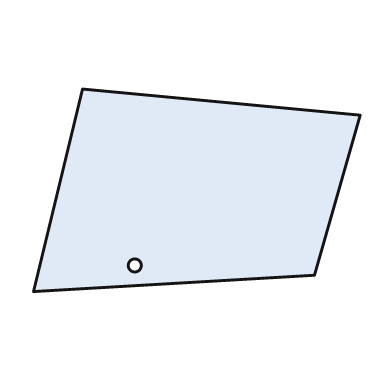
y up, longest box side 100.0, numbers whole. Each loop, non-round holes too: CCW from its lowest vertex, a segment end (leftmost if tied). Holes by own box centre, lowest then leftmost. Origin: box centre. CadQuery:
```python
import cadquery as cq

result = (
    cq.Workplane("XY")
    .moveTo(-50.0, -31.0)
    .lineTo(36.0, -26.0)
    .lineTo(50.0, 23.0)
    .lineTo(-35.0, 31.0)
    .close()
    .moveTo(-19.0, -23.0)
    .circle(2.0)
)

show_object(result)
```